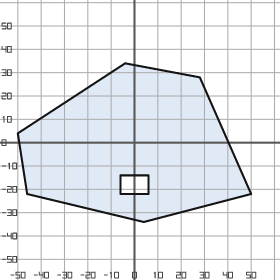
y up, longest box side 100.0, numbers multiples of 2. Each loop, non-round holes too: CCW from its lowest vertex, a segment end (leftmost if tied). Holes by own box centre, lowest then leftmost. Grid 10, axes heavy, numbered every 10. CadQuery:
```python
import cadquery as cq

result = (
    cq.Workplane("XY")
    .moveTo(4.0, -34.0)
    .lineTo(50.0, -22.0)
    .lineTo(28.0, 28.0)
    .lineTo(-4.0, 34.0)
    .lineTo(-50.0, 4.0)
    .lineTo(-46.0, -22.0)
    .close()
    .moveTo(-6.0, -22.0)
    .lineTo(6.0, -22.0)
    .lineTo(6.0, -14.0)
    .lineTo(-6.0, -14.0)
    .close()
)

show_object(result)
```